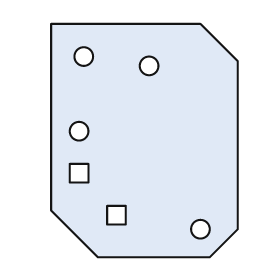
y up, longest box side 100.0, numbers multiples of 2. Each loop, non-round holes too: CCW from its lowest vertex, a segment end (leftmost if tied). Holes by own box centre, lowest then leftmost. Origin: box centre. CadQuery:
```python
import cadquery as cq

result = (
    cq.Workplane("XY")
    .moveTo(-20.0, -50.0)
    .lineTo(28.0, -50.0)
    .lineTo(40.0, -38.0)
    .lineTo(40.0, 34.0)
    .lineTo(24.0, 50.0)
    .lineTo(-40.0, 50.0)
    .lineTo(-40.0, -30.0)
    .close()
    .moveTo(24.0, -38.0)
    .circle(4.0)
    .moveTo(-16.0, -36.0)
    .lineTo(-8.0, -36.0)
    .lineTo(-8.0, -28.0)
    .lineTo(-16.0, -28.0)
    .close()
    .moveTo(-32.0, -18.0)
    .lineTo(-24.0, -18.0)
    .lineTo(-24.0, -10.0)
    .lineTo(-32.0, -10.0)
    .close()
    .moveTo(-28.0, 4.0)
    .circle(4.0)
    .moveTo(2.0, 32.0)
    .circle(4.0)
    .moveTo(-26.0, 36.0)
    .circle(4.0)
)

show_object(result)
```